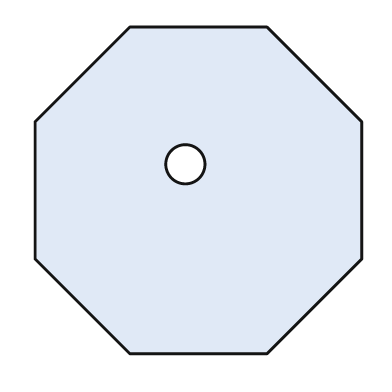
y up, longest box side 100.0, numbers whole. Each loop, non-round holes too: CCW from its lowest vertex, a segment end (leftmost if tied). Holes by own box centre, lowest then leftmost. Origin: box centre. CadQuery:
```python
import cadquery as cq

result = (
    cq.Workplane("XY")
    .moveTo(-21.0, -50.0)
    .lineTo(21.0, -50.0)
    .lineTo(50.0, -21.0)
    .lineTo(50.0, 21.0)
    .lineTo(21.0, 50.0)
    .lineTo(-21.0, 50.0)
    .lineTo(-50.0, 21.0)
    .lineTo(-50.0, -21.0)
    .close()
    .moveTo(-4.0, 8.0)
    .circle(6.0)
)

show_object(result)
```